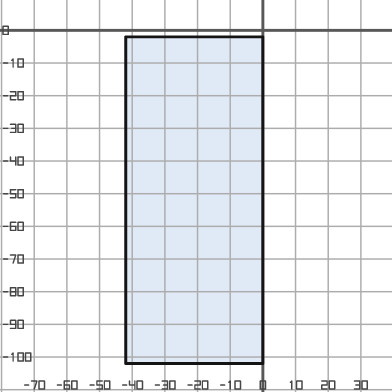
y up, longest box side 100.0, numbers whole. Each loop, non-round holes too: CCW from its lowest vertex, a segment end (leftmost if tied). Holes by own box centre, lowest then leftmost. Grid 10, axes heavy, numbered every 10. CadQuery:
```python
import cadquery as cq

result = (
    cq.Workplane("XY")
    .moveTo(-42.0, -102.0)
    .lineTo(0.0, -102.0)
    .lineTo(0.0, -2.0)
    .lineTo(-42.0, -2.0)
    .close()
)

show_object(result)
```